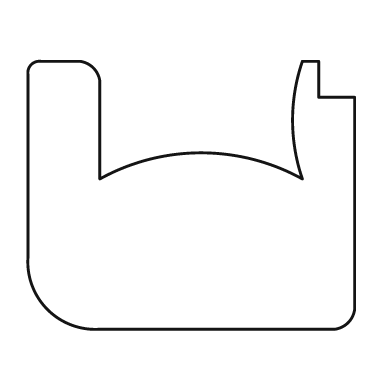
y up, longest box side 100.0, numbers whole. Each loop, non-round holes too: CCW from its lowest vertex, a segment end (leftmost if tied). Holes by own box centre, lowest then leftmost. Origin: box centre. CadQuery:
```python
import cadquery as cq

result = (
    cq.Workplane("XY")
    .moveTo(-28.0, -41.0)
    .lineTo(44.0, -41.0)
    .threePointArc((48.0, -39.0), (50.0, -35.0))
    .lineTo(50.0, 30.0)
    .lineTo(39.0, 30.0)
    .lineTo(39.0, 41.0)
    .lineTo(34.0, 41.0)
    .threePointArc((31.0, 23.0), (34.0, 5.0))
    .threePointArc((3.0, 13.0), (-28.0, 5.0))
    .lineTo(-28.0, 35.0)
    .threePointArc((-30.0, 39.0), (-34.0, 41.0))
    .lineTo(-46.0, 41.0)
    .threePointArc((-49.0, 40.0), (-50.0, 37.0))
    .lineTo(-50.0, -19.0)
    .threePointArc((-44.0, -35.0), (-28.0, -41.0))
    .close()
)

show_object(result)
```